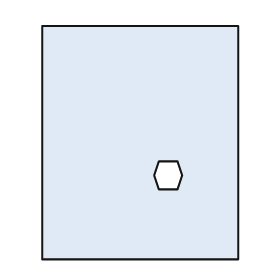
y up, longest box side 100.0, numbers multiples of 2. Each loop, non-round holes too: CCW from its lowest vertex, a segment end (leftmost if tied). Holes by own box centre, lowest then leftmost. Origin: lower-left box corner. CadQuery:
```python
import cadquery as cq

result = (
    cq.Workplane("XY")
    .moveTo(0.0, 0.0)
    .lineTo(84.0, 0.0)
    .lineTo(84.0, 100.0)
    .lineTo(0.0, 100.0)
    .close()
    .moveTo(50.0, 30.0)
    .lineTo(58.0, 30.0)
    .lineTo(60.0, 36.0)
    .lineTo(58.0, 42.0)
    .lineTo(50.0, 42.0)
    .lineTo(48.0, 36.0)
    .close()
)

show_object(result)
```